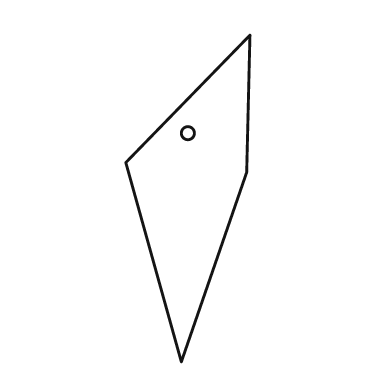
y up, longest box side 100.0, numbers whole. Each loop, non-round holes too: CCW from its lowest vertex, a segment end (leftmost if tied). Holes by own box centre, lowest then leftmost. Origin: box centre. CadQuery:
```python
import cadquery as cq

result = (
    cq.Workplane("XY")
    .moveTo(-2.0, -50.0)
    .lineTo(18.0, 8.0)
    .lineTo(19.0, 50.0)
    .lineTo(-19.0, 11.0)
    .close()
    .moveTo(0.0, 20.0)
    .circle(2.0)
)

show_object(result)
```